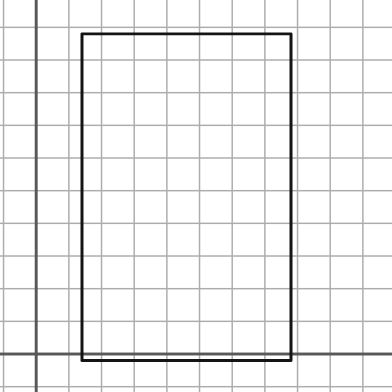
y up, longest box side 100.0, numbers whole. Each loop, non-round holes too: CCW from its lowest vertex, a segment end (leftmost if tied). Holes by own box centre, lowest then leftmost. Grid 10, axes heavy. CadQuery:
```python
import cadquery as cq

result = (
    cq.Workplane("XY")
    .moveTo(14.0, -2.0)
    .lineTo(78.0, -2.0)
    .lineTo(78.0, 98.0)
    .lineTo(14.0, 98.0)
    .close()
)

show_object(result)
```